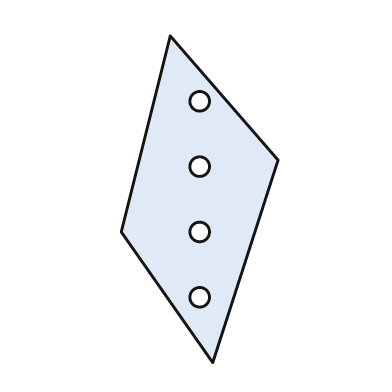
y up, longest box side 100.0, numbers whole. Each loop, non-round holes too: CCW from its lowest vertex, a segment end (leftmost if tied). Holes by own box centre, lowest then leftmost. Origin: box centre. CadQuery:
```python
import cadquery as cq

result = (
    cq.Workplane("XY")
    .moveTo(4.0, -50.0)
    .lineTo(24.0, 12.0)
    .lineTo(-9.0, 50.0)
    .lineTo(-24.0, -10.0)
    .close()
    .moveTo(0.0, -30.0)
    .circle(3.0)
    .moveTo(0.0, -10.0)
    .circle(3.0)
    .moveTo(0.0, 10.0)
    .circle(3.0)
    .moveTo(0.0, 30.0)
    .circle(3.0)
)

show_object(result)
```